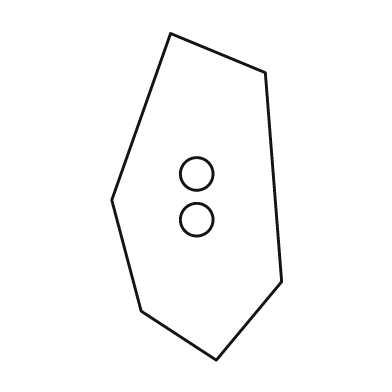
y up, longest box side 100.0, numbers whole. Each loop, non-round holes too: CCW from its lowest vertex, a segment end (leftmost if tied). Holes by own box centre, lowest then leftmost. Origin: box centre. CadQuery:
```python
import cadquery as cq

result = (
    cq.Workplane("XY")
    .moveTo(6.0, -50.0)
    .lineTo(26.0, -26.0)
    .lineTo(21.0, 38.0)
    .lineTo(-8.0, 50.0)
    .lineTo(-26.0, -1.0)
    .lineTo(-17.0, -35.0)
    .close()
    .moveTo(0.0, -7.0)
    .circle(5.0)
    .moveTo(0.0, 7.0)
    .circle(5.0)
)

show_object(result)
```